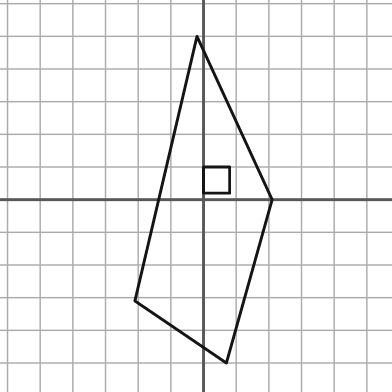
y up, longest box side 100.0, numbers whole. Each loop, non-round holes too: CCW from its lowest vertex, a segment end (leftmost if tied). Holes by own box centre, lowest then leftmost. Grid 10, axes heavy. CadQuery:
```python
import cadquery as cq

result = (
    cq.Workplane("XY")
    .moveTo(7.0, -50.0)
    .lineTo(21.0, 0.0)
    .lineTo(-2.0, 50.0)
    .lineTo(-21.0, -31.0)
    .close()
    .moveTo(0.0, 2.0)
    .lineTo(8.0, 2.0)
    .lineTo(8.0, 10.0)
    .lineTo(0.0, 10.0)
    .close()
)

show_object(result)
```